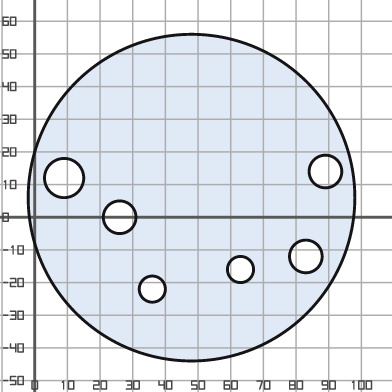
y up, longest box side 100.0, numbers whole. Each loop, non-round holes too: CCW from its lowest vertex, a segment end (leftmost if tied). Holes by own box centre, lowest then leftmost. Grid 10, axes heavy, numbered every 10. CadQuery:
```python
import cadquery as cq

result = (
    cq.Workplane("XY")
    .moveTo(48.0, 6.0)
    .circle(50.0)
    .moveTo(36.0, -22.0)
    .circle(4.0)
    .moveTo(63.0, -16.0)
    .circle(4.0)
    .moveTo(83.0, -12.0)
    .circle(5.0)
    .moveTo(26.0, 0.0)
    .circle(5.0)
    .moveTo(9.0, 12.0)
    .circle(6.0)
    .moveTo(89.0, 14.0)
    .circle(5.0)
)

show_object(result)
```